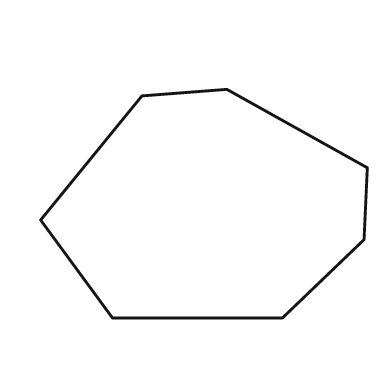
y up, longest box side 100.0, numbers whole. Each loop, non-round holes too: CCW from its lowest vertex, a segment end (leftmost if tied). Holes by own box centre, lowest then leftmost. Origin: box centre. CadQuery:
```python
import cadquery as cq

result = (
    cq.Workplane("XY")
    .moveTo(-28.0, -35.0)
    .lineTo(24.0, -35.0)
    .lineTo(49.0, -11.0)
    .lineTo(50.0, 11.0)
    .lineTo(7.0, 35.0)
    .lineTo(-19.0, 33.0)
    .lineTo(-50.0, -5.0)
    .close()
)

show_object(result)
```